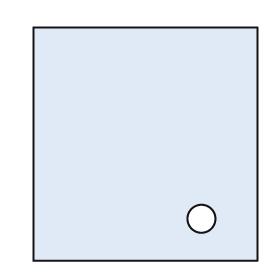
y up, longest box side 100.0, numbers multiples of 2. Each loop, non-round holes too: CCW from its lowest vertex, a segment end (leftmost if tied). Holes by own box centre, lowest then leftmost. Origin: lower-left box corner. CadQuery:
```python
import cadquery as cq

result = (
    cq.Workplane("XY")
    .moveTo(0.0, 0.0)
    .lineTo(96.0, 0.0)
    .lineTo(96.0, 100.0)
    .lineTo(0.0, 100.0)
    .close()
    .moveTo(72.0, 18.0)
    .circle(6.0)
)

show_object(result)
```